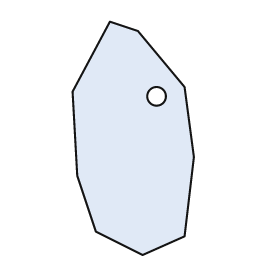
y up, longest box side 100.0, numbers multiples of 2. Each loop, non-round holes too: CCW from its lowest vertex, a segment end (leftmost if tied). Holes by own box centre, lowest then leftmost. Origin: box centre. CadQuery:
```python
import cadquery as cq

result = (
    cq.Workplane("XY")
    .moveTo(4.0, -50.0)
    .lineTo(22.0, -42.0)
    .lineTo(26.0, -8.0)
    .lineTo(22.0, 22.0)
    .lineTo(2.0, 46.0)
    .lineTo(-10.0, 50.0)
    .lineTo(-26.0, 20.0)
    .lineTo(-24.0, -16.0)
    .lineTo(-16.0, -40.0)
    .close()
    .moveTo(10.0, 18.0)
    .circle(4.0)
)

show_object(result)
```